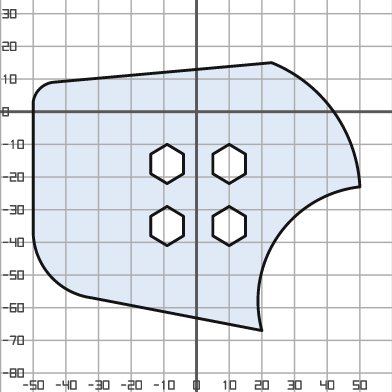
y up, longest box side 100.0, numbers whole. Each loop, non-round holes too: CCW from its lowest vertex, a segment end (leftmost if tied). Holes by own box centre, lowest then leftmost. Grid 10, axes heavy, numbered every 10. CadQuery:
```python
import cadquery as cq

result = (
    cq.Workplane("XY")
    .moveTo(20.0, -67.0)
    .threePointArc((25.0, -38.0), (50.0, -23.0))
    .threePointArc((42.0, 0.0), (23.0, 15.0))
    .lineTo(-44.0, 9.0)
    .threePointArc((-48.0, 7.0), (-50.0, 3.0))
    .lineTo(-50.0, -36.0)
    .threePointArc((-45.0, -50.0), (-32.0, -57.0))
    .close()
    .moveTo(-9.0, -41.0)
    .lineTo(-4.0, -38.0)
    .lineTo(-4.0, -32.0)
    .lineTo(-9.0, -29.0)
    .lineTo(-14.0, -32.0)
    .lineTo(-14.0, -38.0)
    .close()
    .moveTo(10.0, -41.0)
    .lineTo(15.0, -38.0)
    .lineTo(15.0, -32.0)
    .lineTo(10.0, -29.0)
    .lineTo(5.0, -32.0)
    .lineTo(5.0, -38.0)
    .close()
    .moveTo(-9.0, -22.0)
    .lineTo(-4.0, -19.0)
    .lineTo(-4.0, -13.0)
    .lineTo(-9.0, -10.0)
    .lineTo(-14.0, -13.0)
    .lineTo(-14.0, -19.0)
    .close()
    .moveTo(10.0, -22.0)
    .lineTo(15.0, -19.0)
    .lineTo(15.0, -13.0)
    .lineTo(10.0, -10.0)
    .lineTo(5.0, -13.0)
    .lineTo(5.0, -19.0)
    .close()
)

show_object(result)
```